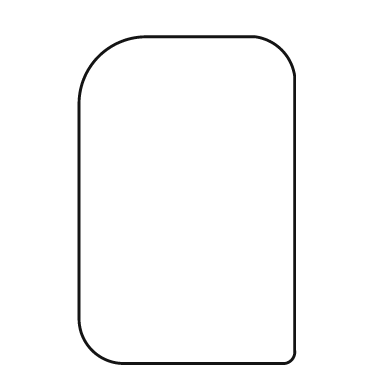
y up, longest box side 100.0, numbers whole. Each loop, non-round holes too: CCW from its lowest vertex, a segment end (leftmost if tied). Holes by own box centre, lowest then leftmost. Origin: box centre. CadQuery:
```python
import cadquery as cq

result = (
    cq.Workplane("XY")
    .moveTo(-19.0, -50.0)
    .lineTo(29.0, -50.0)
    .threePointArc((32.0, -49.0), (33.0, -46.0))
    .lineTo(33.0, 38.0)
    .threePointArc((29.0, 46.0), (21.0, 50.0))
    .lineTo(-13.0, 50.0)
    .threePointArc((-27.0, 44.0), (-33.0, 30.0))
    .lineTo(-33.0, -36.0)
    .threePointArc((-29.0, -46.0), (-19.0, -50.0))
    .close()
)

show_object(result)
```